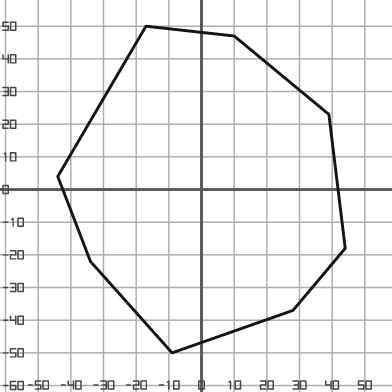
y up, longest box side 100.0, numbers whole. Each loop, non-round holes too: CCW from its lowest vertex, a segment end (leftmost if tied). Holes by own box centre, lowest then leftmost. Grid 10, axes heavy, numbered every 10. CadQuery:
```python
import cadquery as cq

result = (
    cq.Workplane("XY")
    .moveTo(-9.0, -50.0)
    .lineTo(28.0, -37.0)
    .lineTo(44.0, -18.0)
    .lineTo(39.0, 23.0)
    .lineTo(10.0, 47.0)
    .lineTo(-17.0, 50.0)
    .lineTo(-44.0, 4.0)
    .lineTo(-34.0, -22.0)
    .close()
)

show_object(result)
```